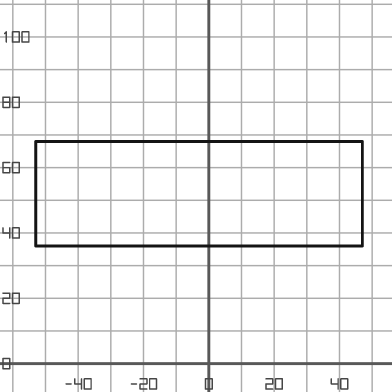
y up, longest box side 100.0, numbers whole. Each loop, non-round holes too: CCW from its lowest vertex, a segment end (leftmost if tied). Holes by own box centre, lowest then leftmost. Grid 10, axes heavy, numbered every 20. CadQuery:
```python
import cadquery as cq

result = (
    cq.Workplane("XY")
    .moveTo(-53.0, 36.0)
    .lineTo(47.0, 36.0)
    .lineTo(47.0, 68.0)
    .lineTo(-53.0, 68.0)
    .close()
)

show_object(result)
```